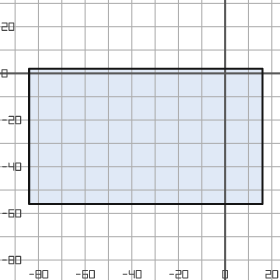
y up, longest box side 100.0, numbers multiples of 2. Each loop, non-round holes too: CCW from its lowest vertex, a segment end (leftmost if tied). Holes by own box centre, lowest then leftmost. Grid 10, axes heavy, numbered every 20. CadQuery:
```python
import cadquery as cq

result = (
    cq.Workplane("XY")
    .moveTo(-84.0, -56.0)
    .lineTo(16.0, -56.0)
    .lineTo(16.0, 2.0)
    .lineTo(-84.0, 2.0)
    .close()
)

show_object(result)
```